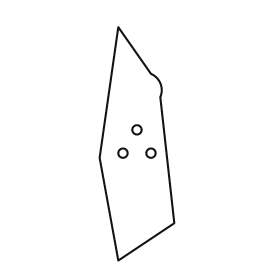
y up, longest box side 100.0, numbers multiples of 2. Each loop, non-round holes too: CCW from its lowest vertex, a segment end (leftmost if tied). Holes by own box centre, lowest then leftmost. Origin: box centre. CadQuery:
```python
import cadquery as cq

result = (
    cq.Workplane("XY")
    .moveTo(-8.0, -50.0)
    .lineTo(16.0, -34.0)
    .lineTo(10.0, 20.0)
    .threePointArc((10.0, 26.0), (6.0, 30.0))
    .lineTo(-8.0, 50.0)
    .lineTo(-16.0, -6.0)
    .close()
    .moveTo(-6.0, -4.0)
    .circle(2.0)
    .moveTo(6.0, -4.0)
    .circle(2.0)
    .moveTo(0.0, 6.0)
    .circle(2.0)
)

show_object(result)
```